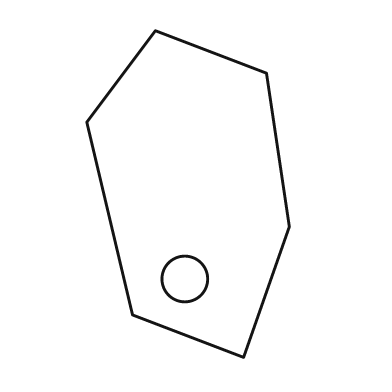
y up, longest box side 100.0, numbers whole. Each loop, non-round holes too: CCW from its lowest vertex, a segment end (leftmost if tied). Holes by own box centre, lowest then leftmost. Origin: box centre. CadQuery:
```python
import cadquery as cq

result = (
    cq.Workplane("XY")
    .moveTo(17.0, -50.0)
    .lineTo(31.0, -10.0)
    .lineTo(24.0, 37.0)
    .lineTo(-10.0, 50.0)
    .lineTo(-31.0, 22.0)
    .lineTo(-17.0, -37.0)
    .close()
    .moveTo(-1.0, -26.0)
    .circle(7.0)
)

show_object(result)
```